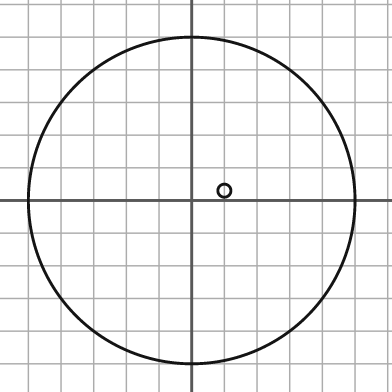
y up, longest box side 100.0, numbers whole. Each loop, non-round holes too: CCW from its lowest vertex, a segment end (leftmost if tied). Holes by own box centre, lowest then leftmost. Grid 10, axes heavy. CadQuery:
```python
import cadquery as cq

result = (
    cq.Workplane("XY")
    .moveTo(0.0, 0.0)
    .circle(50.0)
    .moveTo(10.0, 3.0)
    .circle(2.0)
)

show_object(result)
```